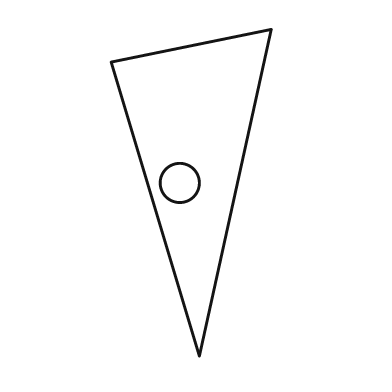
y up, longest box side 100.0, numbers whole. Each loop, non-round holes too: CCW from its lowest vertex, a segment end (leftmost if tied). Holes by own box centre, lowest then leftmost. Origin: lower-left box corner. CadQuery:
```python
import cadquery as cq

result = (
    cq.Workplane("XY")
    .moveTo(27.0, 0.0)
    .lineTo(49.0, 100.0)
    .lineTo(0.0, 90.0)
    .close()
    .moveTo(21.0, 53.0)
    .circle(6.0)
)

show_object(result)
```